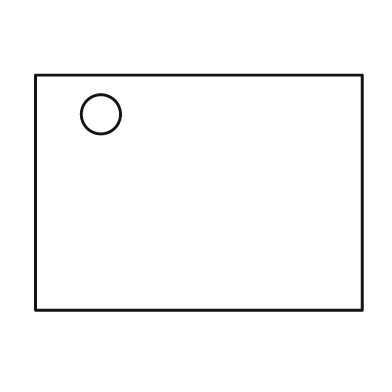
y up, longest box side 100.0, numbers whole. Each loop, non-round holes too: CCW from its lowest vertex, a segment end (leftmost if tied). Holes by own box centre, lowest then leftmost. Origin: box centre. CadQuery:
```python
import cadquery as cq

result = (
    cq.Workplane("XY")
    .moveTo(-50.0, -36.0)
    .lineTo(50.0, -36.0)
    .lineTo(50.0, 36.0)
    .lineTo(-50.0, 36.0)
    .close()
    .moveTo(-30.0, 24.0)
    .circle(6.0)
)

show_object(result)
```